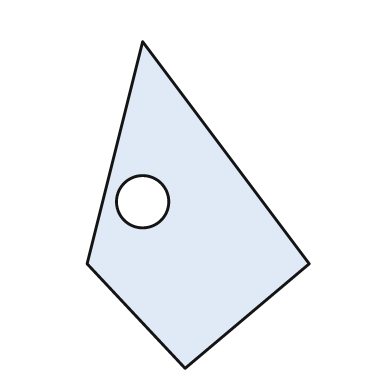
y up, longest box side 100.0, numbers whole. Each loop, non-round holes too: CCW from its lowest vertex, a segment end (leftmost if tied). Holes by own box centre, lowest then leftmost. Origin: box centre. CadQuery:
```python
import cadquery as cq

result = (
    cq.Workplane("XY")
    .moveTo(-4.0, -50.0)
    .lineTo(34.0, -18.0)
    .lineTo(-17.0, 50.0)
    .lineTo(-34.0, -18.0)
    .close()
    .moveTo(-17.0, 1.0)
    .circle(8.0)
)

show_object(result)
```